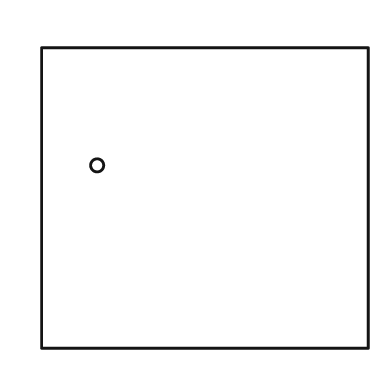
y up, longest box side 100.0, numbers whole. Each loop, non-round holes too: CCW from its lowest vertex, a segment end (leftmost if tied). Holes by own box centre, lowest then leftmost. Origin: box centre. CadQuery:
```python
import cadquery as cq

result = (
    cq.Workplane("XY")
    .moveTo(-50.0, -46.0)
    .lineTo(50.0, -46.0)
    .lineTo(50.0, 46.0)
    .lineTo(-50.0, 46.0)
    .close()
    .moveTo(-33.0, 10.0)
    .circle(2.0)
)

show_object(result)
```